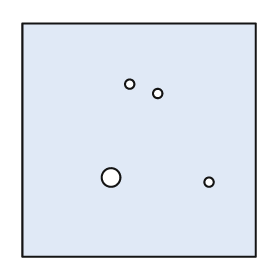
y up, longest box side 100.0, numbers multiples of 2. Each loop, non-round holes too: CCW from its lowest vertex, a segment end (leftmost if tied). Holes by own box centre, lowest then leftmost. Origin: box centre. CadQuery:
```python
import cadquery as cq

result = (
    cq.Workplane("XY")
    .moveTo(-50.0, -50.0)
    .lineTo(50.0, -50.0)
    .lineTo(50.0, 50.0)
    .lineTo(-50.0, 50.0)
    .close()
    .moveTo(30.0, -18.0)
    .circle(2.0)
    .moveTo(-12.0, -16.0)
    .circle(4.0)
    .moveTo(8.0, 20.0)
    .circle(2.0)
    .moveTo(-4.0, 24.0)
    .circle(2.0)
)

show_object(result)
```